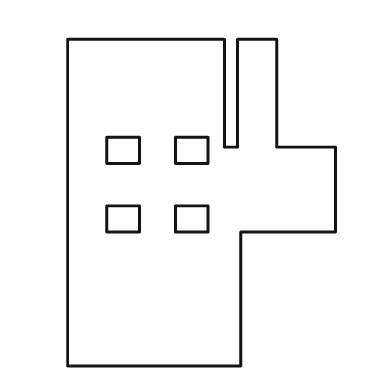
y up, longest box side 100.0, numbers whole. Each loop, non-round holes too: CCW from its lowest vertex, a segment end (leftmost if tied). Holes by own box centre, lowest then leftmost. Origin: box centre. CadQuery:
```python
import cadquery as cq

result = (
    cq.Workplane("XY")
    .moveTo(-41.0, -50.0)
    .lineTo(12.0, -50.0)
    .lineTo(12.0, -9.0)
    .lineTo(41.0, -9.0)
    .lineTo(41.0, 17.0)
    .lineTo(23.0, 17.0)
    .lineTo(23.0, 50.0)
    .lineTo(11.0, 50.0)
    .lineTo(11.0, 17.0)
    .lineTo(7.0, 17.0)
    .lineTo(7.0, 50.0)
    .lineTo(-41.0, 50.0)
    .close()
    .moveTo(-29.0, -9.0)
    .lineTo(-19.0, -9.0)
    .lineTo(-19.0, -1.0)
    .lineTo(-29.0, -1.0)
    .close()
    .moveTo(-8.0, -9.0)
    .lineTo(2.0, -9.0)
    .lineTo(2.0, -1.0)
    .lineTo(-8.0, -1.0)
    .close()
    .moveTo(-29.0, 12.0)
    .lineTo(-19.0, 12.0)
    .lineTo(-19.0, 20.0)
    .lineTo(-29.0, 20.0)
    .close()
    .moveTo(-8.0, 12.0)
    .lineTo(2.0, 12.0)
    .lineTo(2.0, 20.0)
    .lineTo(-8.0, 20.0)
    .close()
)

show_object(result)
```